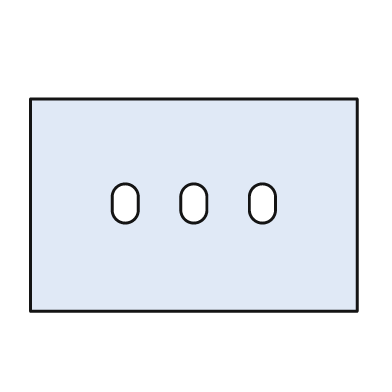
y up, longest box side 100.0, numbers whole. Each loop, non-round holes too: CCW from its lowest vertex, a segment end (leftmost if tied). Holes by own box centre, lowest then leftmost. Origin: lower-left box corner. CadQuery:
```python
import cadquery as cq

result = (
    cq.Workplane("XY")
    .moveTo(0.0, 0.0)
    .lineTo(100.0, 0.0)
    .lineTo(100.0, 65.0)
    .lineTo(0.0, 65.0)
    .close()
    .moveTo(25.0, 31.0)
    .threePointArc((29.0, 27.0), (33.0, 31.0))
    .lineTo(33.0, 35.0)
    .threePointArc((29.0, 39.0), (25.0, 35.0))
    .close()
    .moveTo(46.0, 31.0)
    .threePointArc((50.0, 27.0), (54.0, 31.0))
    .lineTo(54.0, 35.0)
    .threePointArc((50.0, 39.0), (46.0, 35.0))
    .close()
    .moveTo(67.0, 31.0)
    .threePointArc((71.0, 27.0), (75.0, 31.0))
    .lineTo(75.0, 35.0)
    .threePointArc((71.0, 39.0), (67.0, 35.0))
    .close()
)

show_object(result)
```